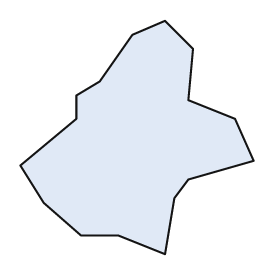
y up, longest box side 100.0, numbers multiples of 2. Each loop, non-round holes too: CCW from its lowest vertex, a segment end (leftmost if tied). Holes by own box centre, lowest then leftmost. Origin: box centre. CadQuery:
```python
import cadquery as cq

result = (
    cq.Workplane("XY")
    .moveTo(12.0, -50.0)
    .lineTo(16.0, -26.0)
    .lineTo(22.0, -18.0)
    .lineTo(50.0, -10.0)
    .lineTo(42.0, 8.0)
    .lineTo(22.0, 16.0)
    .lineTo(24.0, 38.0)
    .lineTo(12.0, 50.0)
    .lineTo(-2.0, 44.0)
    .lineTo(-16.0, 24.0)
    .lineTo(-26.0, 18.0)
    .lineTo(-26.0, 8.0)
    .lineTo(-50.0, -12.0)
    .lineTo(-40.0, -28.0)
    .lineTo(-24.0, -42.0)
    .lineTo(-8.0, -42.0)
    .close()
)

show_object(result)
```